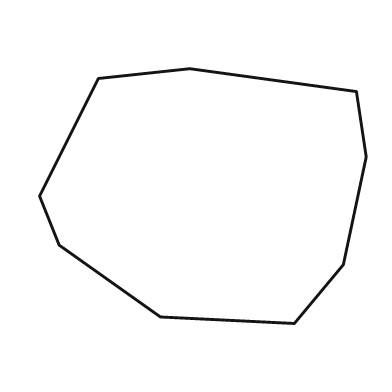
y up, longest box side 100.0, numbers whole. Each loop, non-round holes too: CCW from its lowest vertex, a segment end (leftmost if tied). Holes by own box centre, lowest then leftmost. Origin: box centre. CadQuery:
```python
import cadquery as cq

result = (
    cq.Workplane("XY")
    .moveTo(28.0, -39.0)
    .lineTo(43.0, -21.0)
    .lineTo(50.0, 12.0)
    .lineTo(47.0, 32.0)
    .lineTo(-4.0, 39.0)
    .lineTo(-32.0, 36.0)
    .lineTo(-50.0, 0.0)
    .lineTo(-44.0, -15.0)
    .lineTo(-13.0, -37.0)
    .close()
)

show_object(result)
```